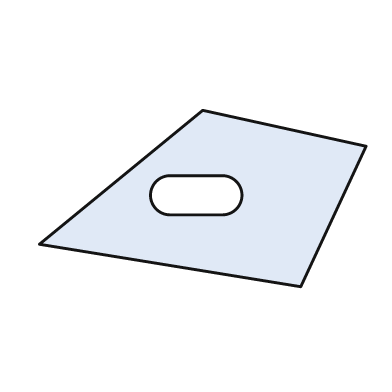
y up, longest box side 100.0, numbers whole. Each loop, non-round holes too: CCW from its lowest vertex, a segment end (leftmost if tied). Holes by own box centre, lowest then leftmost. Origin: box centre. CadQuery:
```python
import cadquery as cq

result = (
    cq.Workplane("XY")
    .moveTo(30.0, -27.0)
    .lineTo(50.0, 16.0)
    .lineTo(0.0, 27.0)
    .lineTo(-50.0, -14.0)
    .close()
    .moveTo(-10.0, -5.0)
    .lineTo(6.0, -5.0)
    .threePointArc((12.0, 1.0), (6.0, 7.0))
    .lineTo(-10.0, 7.0)
    .threePointArc((-16.0, 1.0), (-10.0, -5.0))
    .close()
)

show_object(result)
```